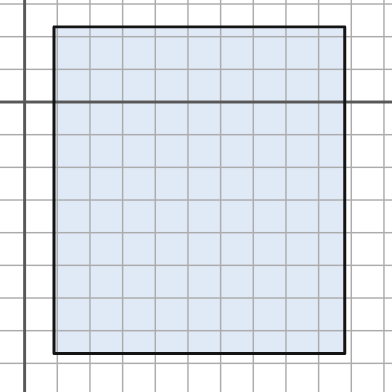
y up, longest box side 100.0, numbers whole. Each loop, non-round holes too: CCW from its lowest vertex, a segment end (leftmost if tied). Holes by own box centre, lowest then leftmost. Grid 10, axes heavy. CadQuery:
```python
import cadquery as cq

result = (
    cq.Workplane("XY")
    .moveTo(9.0, -77.0)
    .lineTo(98.0, -77.0)
    .lineTo(98.0, 23.0)
    .lineTo(9.0, 23.0)
    .close()
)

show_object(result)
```